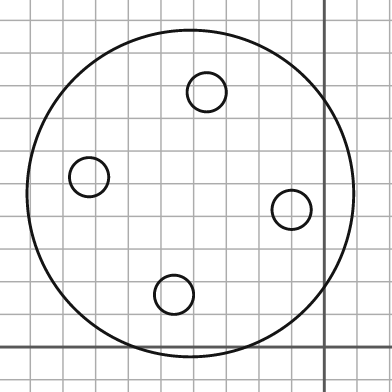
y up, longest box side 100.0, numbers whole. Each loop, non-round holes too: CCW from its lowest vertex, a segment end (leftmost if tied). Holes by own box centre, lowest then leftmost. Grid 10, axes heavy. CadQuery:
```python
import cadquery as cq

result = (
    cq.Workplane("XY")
    .moveTo(-41.0, 47.0)
    .circle(50.0)
    .moveTo(-46.0, 16.0)
    .circle(6.0)
    .moveTo(-10.0, 42.0)
    .circle(6.0)
    .moveTo(-72.0, 52.0)
    .circle(6.0)
    .moveTo(-36.0, 78.0)
    .circle(6.0)
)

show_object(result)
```